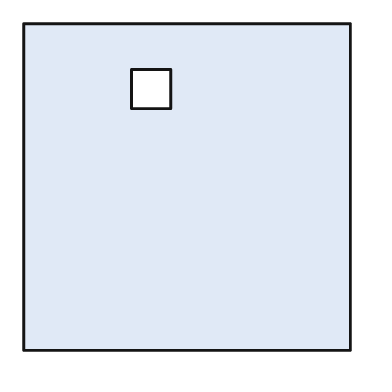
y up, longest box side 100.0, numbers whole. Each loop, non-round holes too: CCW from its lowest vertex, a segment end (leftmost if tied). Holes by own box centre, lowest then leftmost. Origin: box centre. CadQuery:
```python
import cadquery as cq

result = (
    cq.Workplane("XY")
    .moveTo(-50.0, -50.0)
    .lineTo(50.0, -50.0)
    .lineTo(50.0, 50.0)
    .lineTo(-50.0, 50.0)
    .close()
    .moveTo(-17.0, 24.0)
    .lineTo(-5.0, 24.0)
    .lineTo(-5.0, 36.0)
    .lineTo(-17.0, 36.0)
    .close()
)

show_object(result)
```